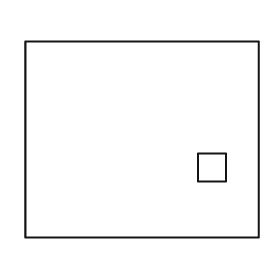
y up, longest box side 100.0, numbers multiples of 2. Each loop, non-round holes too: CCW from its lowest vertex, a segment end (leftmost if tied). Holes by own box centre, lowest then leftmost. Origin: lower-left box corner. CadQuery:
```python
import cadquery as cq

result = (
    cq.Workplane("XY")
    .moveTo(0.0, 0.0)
    .lineTo(100.0, 0.0)
    .lineTo(100.0, 84.0)
    .lineTo(0.0, 84.0)
    .close()
    .moveTo(74.0, 24.0)
    .lineTo(86.0, 24.0)
    .lineTo(86.0, 36.0)
    .lineTo(74.0, 36.0)
    .close()
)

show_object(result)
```